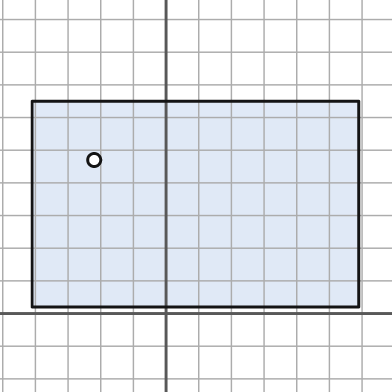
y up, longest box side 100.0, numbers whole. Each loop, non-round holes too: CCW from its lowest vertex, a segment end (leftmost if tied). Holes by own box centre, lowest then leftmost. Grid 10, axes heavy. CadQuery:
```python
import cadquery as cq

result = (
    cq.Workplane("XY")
    .moveTo(-41.0, 2.0)
    .lineTo(59.0, 2.0)
    .lineTo(59.0, 65.0)
    .lineTo(-41.0, 65.0)
    .close()
    .moveTo(-22.0, 47.0)
    .circle(2.0)
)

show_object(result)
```